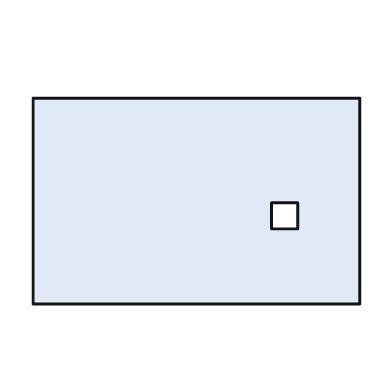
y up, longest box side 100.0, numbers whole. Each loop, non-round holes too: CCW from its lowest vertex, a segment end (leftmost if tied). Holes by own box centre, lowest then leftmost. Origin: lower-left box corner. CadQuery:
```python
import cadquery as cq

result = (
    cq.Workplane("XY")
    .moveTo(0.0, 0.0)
    .lineTo(100.0, 0.0)
    .lineTo(100.0, 63.0)
    .lineTo(0.0, 63.0)
    .close()
    .moveTo(73.0, 23.0)
    .lineTo(81.0, 23.0)
    .lineTo(81.0, 31.0)
    .lineTo(73.0, 31.0)
    .close()
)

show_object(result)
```